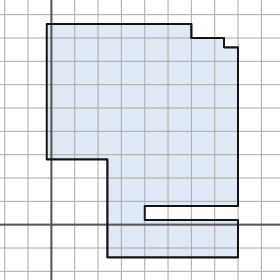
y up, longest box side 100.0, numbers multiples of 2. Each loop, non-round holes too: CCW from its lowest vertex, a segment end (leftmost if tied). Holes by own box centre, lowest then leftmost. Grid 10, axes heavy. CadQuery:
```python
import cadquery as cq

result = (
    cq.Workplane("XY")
    .moveTo(24.0, -14.0)
    .lineTo(80.0, -14.0)
    .lineTo(80.0, 2.0)
    .lineTo(40.0, 2.0)
    .lineTo(40.0, 8.0)
    .lineTo(80.0, 8.0)
    .lineTo(80.0, 76.0)
    .lineTo(74.0, 76.0)
    .lineTo(74.0, 80.0)
    .lineTo(60.0, 80.0)
    .lineTo(60.0, 86.0)
    .lineTo(-2.0, 86.0)
    .lineTo(-2.0, 28.0)
    .lineTo(24.0, 28.0)
    .close()
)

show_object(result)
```